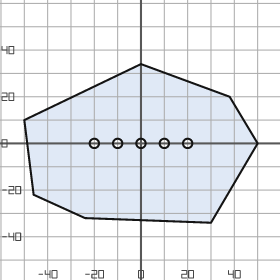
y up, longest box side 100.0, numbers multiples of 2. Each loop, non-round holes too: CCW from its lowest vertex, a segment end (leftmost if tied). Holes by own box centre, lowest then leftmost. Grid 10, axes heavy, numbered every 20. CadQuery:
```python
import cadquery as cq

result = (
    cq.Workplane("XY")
    .moveTo(30.0, -34.0)
    .lineTo(50.0, 0.0)
    .lineTo(38.0, 20.0)
    .lineTo(0.0, 34.0)
    .lineTo(-50.0, 10.0)
    .lineTo(-46.0, -22.0)
    .lineTo(-24.0, -32.0)
    .close()
    .moveTo(-20.0, 0.0)
    .circle(2.0)
    .moveTo(-10.0, 0.0)
    .circle(2.0)
    .moveTo(0.0, 0.0)
    .circle(2.0)
    .moveTo(10.0, 0.0)
    .circle(2.0)
    .moveTo(20.0, 0.0)
    .circle(2.0)
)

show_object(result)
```